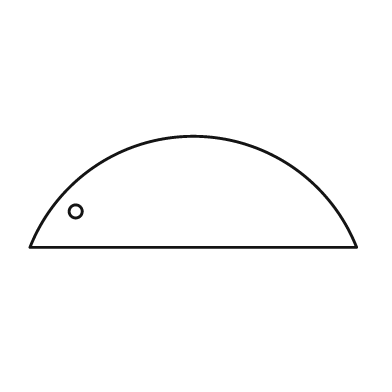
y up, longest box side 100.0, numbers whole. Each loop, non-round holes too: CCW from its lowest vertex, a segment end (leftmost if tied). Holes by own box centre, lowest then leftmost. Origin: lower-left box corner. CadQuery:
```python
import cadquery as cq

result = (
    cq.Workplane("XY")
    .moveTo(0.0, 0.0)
    .lineTo(100.0, 0.0)
    .threePointArc((50.0, 34.0), (0.0, 0.0))
    .close()
    .moveTo(14.0, 11.0)
    .circle(2.0)
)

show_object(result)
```